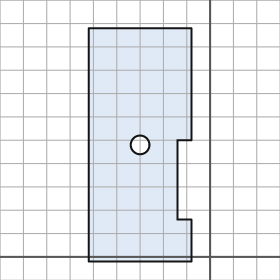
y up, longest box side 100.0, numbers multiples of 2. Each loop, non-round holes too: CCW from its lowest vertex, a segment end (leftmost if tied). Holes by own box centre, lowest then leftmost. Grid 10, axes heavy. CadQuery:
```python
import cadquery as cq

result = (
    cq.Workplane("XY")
    .moveTo(-52.0, -2.0)
    .lineTo(-8.0, -2.0)
    .lineTo(-8.0, 16.0)
    .lineTo(-14.0, 16.0)
    .lineTo(-14.0, 50.0)
    .lineTo(-8.0, 50.0)
    .lineTo(-8.0, 98.0)
    .lineTo(-52.0, 98.0)
    .close()
    .moveTo(-30.0, 48.0)
    .circle(4.0)
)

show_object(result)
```